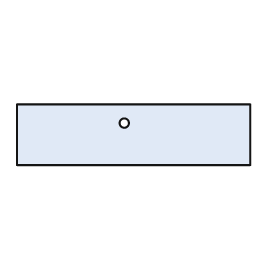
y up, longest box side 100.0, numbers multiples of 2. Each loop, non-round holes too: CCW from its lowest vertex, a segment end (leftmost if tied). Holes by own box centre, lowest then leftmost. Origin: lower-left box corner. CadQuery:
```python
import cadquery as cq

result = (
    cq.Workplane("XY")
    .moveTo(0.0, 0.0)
    .lineTo(100.0, 0.0)
    .lineTo(100.0, 26.0)
    .lineTo(0.0, 26.0)
    .close()
    .moveTo(46.0, 18.0)
    .circle(2.0)
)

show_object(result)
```